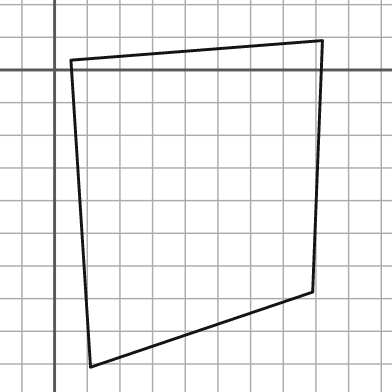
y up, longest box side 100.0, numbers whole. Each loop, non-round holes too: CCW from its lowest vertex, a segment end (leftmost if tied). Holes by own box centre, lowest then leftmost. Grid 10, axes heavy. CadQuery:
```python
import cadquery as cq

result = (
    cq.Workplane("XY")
    .moveTo(11.0, -91.0)
    .lineTo(79.0, -68.0)
    .lineTo(82.0, 9.0)
    .lineTo(5.0, 3.0)
    .close()
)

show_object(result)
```